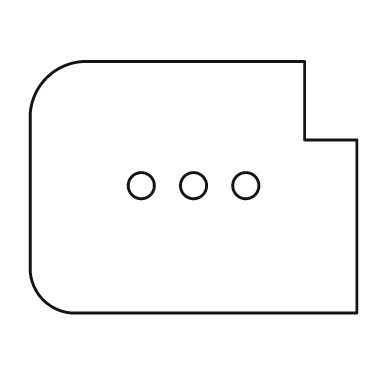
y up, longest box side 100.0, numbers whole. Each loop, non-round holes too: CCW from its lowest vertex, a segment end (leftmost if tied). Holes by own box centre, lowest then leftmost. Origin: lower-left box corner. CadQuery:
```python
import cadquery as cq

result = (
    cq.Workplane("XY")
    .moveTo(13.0, 0.0)
    .lineTo(100.0, 0.0)
    .lineTo(100.0, 53.0)
    .lineTo(84.0, 53.0)
    .lineTo(84.0, 77.0)
    .lineTo(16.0, 77.0)
    .threePointArc((5.0, 72.0), (0.0, 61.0))
    .lineTo(0.0, 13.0)
    .threePointArc((4.0, 4.0), (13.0, 0.0))
    .close()
    .moveTo(34.0, 39.0)
    .circle(4.0)
    .moveTo(50.0, 39.0)
    .circle(4.0)
    .moveTo(66.0, 39.0)
    .circle(4.0)
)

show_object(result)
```